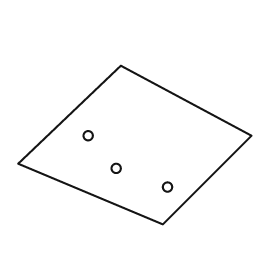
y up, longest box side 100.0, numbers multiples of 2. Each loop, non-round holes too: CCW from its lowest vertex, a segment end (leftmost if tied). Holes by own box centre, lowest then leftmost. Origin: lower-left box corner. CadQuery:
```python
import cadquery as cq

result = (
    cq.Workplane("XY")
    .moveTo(62.0, 0.0)
    .lineTo(100.0, 38.0)
    .lineTo(44.0, 68.0)
    .lineTo(0.0, 26.0)
    .close()
    .moveTo(64.0, 16.0)
    .circle(2.0)
    .moveTo(42.0, 24.0)
    .circle(2.0)
    .moveTo(30.0, 38.0)
    .circle(2.0)
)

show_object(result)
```